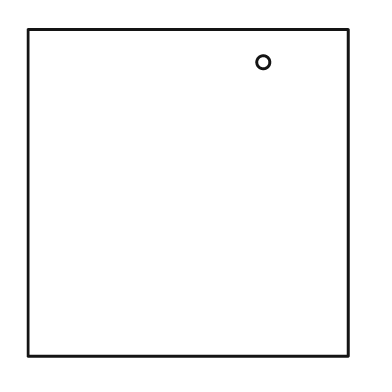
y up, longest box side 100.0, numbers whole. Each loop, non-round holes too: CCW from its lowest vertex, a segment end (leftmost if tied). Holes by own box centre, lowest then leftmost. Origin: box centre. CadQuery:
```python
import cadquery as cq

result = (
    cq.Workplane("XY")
    .moveTo(-49.0, -50.0)
    .lineTo(49.0, -50.0)
    .lineTo(49.0, 50.0)
    .lineTo(-49.0, 50.0)
    .close()
    .moveTo(23.0, 40.0)
    .circle(2.0)
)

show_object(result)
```